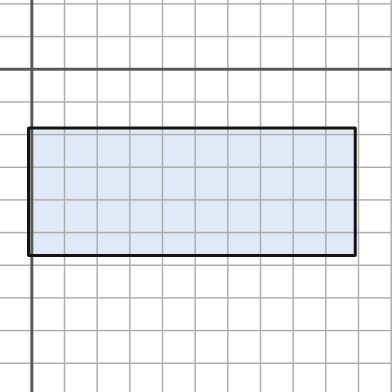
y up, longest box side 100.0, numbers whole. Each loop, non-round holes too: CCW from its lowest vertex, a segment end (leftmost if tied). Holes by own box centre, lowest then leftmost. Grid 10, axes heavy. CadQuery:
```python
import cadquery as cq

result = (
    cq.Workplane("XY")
    .moveTo(-1.0, -57.0)
    .lineTo(99.0, -57.0)
    .lineTo(99.0, -18.0)
    .lineTo(-1.0, -18.0)
    .close()
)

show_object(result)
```